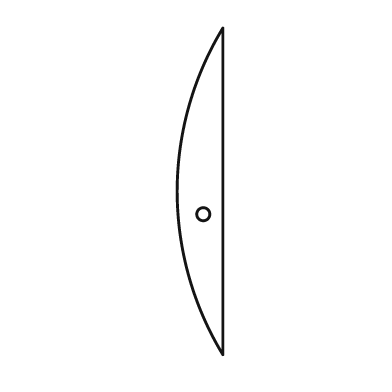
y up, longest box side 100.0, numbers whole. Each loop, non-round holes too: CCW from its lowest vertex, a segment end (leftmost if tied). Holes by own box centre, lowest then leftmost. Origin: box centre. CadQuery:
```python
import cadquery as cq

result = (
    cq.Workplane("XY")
    .moveTo(7.0, -50.0)
    .lineTo(7.0, 50.0)
    .threePointArc((-7.0, 0.0), (7.0, -50.0))
    .close()
    .moveTo(1.0, -7.0)
    .circle(2.0)
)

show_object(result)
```